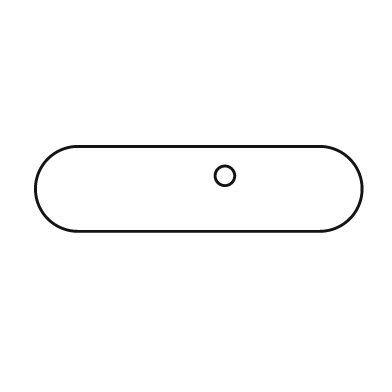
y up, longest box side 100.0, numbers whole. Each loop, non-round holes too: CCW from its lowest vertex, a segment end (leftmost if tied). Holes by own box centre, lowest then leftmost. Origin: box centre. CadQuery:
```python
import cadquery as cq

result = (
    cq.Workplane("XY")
    .moveTo(-37.0, -13.0)
    .lineTo(37.0, -13.0)
    .threePointArc((50.0, 0.0), (37.0, 13.0))
    .lineTo(-37.0, 13.0)
    .threePointArc((-50.0, 0.0), (-37.0, -13.0))
    .close()
    .moveTo(8.0, 4.0)
    .circle(3.0)
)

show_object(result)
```